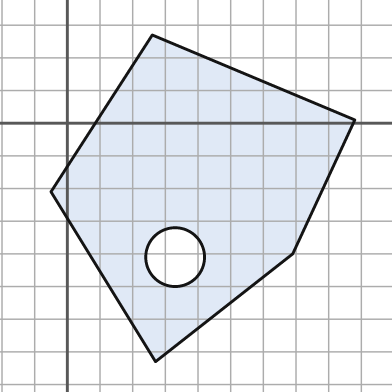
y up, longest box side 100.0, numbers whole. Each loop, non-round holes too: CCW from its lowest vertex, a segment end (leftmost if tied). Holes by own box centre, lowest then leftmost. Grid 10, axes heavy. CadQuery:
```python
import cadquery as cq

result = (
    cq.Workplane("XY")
    .moveTo(27.0, -73.0)
    .lineTo(69.0, -40.0)
    .lineTo(88.0, 1.0)
    .lineTo(26.0, 27.0)
    .lineTo(-5.0, -21.0)
    .close()
    .moveTo(33.0, -41.0)
    .circle(9.0)
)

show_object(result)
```